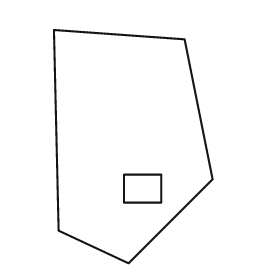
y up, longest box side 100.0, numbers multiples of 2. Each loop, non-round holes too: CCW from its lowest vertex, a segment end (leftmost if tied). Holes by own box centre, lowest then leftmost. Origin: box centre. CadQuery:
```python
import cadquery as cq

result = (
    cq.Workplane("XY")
    .moveTo(-2.0, -50.0)
    .lineTo(34.0, -14.0)
    .lineTo(22.0, 46.0)
    .lineTo(-34.0, 50.0)
    .lineTo(-32.0, -36.0)
    .close()
    .moveTo(-4.0, -24.0)
    .lineTo(12.0, -24.0)
    .lineTo(12.0, -12.0)
    .lineTo(-4.0, -12.0)
    .close()
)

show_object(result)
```